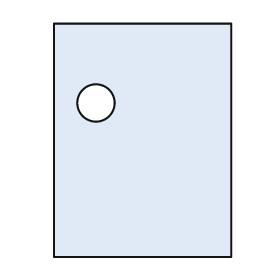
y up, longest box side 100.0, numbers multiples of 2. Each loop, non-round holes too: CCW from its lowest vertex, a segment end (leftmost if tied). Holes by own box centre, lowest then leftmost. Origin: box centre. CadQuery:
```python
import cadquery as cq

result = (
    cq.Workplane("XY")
    .moveTo(-38.0, -50.0)
    .lineTo(38.0, -50.0)
    .lineTo(38.0, 50.0)
    .lineTo(-38.0, 50.0)
    .close()
    .moveTo(-20.0, 16.0)
    .circle(8.0)
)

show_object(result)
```